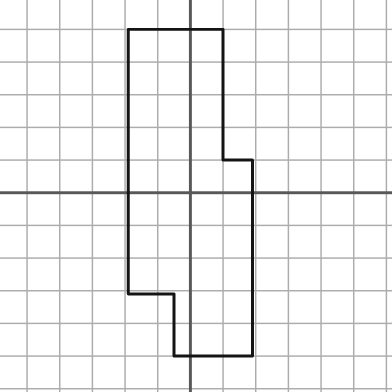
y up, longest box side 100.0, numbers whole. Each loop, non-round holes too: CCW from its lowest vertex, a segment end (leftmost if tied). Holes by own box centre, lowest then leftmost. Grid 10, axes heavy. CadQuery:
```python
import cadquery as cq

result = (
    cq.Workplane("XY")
    .moveTo(-5.0, -50.0)
    .lineTo(19.0, -50.0)
    .lineTo(19.0, 10.0)
    .lineTo(10.0, 10.0)
    .lineTo(10.0, 50.0)
    .lineTo(-19.0, 50.0)
    .lineTo(-19.0, -31.0)
    .lineTo(-5.0, -31.0)
    .close()
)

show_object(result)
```